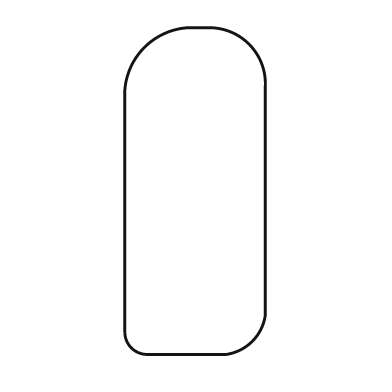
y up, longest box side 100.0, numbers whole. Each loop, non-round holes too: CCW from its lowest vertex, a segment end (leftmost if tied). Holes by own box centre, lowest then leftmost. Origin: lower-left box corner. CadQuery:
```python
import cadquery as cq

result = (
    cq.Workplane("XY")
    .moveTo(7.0, 0.0)
    .lineTo(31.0, 0.0)
    .threePointArc((39.0, 4.0), (43.0, 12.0))
    .lineTo(43.0, 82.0)
    .threePointArc((38.0, 95.0), (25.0, 100.0))
    .lineTo(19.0, 100.0)
    .threePointArc((6.0, 94.0), (0.0, 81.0))
    .lineTo(0.0, 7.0)
    .threePointArc((2.0, 2.0), (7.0, 0.0))
    .close()
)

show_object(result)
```